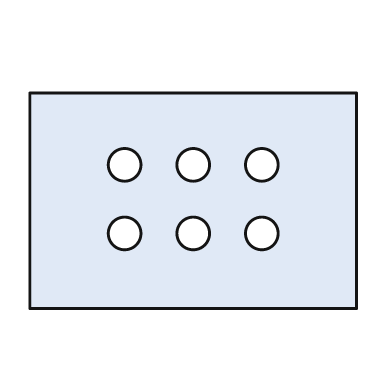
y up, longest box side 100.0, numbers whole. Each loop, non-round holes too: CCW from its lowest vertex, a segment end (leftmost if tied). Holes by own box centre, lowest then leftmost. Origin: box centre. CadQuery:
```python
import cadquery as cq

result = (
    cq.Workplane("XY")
    .moveTo(-50.0, -33.0)
    .lineTo(50.0, -33.0)
    .lineTo(50.0, 33.0)
    .lineTo(-50.0, 33.0)
    .close()
    .moveTo(-21.0, -10.0)
    .circle(5.0)
    .moveTo(0.0, -10.0)
    .circle(5.0)
    .moveTo(21.0, -10.0)
    .circle(5.0)
    .moveTo(-21.0, 11.0)
    .circle(5.0)
    .moveTo(0.0, 11.0)
    .circle(5.0)
    .moveTo(21.0, 11.0)
    .circle(5.0)
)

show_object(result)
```